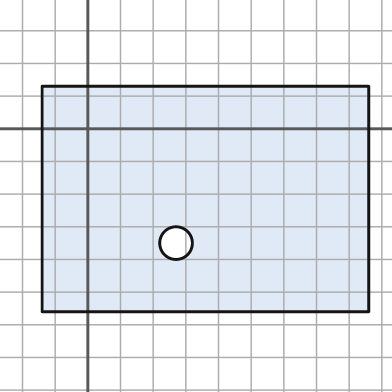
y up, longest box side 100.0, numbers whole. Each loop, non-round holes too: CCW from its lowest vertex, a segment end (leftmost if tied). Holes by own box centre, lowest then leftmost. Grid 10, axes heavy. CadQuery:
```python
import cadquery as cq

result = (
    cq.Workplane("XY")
    .moveTo(-14.0, -56.0)
    .lineTo(86.0, -56.0)
    .lineTo(86.0, 13.0)
    .lineTo(-14.0, 13.0)
    .close()
    .moveTo(27.0, -35.0)
    .circle(5.0)
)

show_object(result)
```